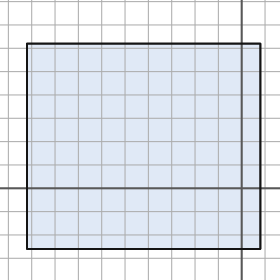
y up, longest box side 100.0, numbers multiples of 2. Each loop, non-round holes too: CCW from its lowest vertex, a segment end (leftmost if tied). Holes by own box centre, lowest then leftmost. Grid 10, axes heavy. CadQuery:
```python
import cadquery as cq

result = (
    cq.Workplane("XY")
    .moveTo(-92.0, -26.0)
    .lineTo(8.0, -26.0)
    .lineTo(8.0, 62.0)
    .lineTo(-92.0, 62.0)
    .close()
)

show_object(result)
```